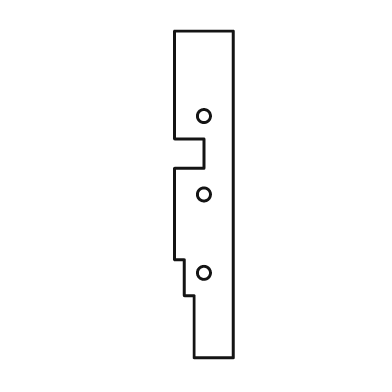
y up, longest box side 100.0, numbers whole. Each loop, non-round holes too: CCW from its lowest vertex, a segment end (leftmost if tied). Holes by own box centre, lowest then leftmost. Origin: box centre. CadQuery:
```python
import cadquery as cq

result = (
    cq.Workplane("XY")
    .moveTo(-3.0, -50.0)
    .lineTo(9.0, -50.0)
    .lineTo(9.0, 50.0)
    .lineTo(-9.0, 50.0)
    .lineTo(-9.0, 17.0)
    .lineTo(0.0, 17.0)
    .lineTo(0.0, 8.0)
    .lineTo(-9.0, 8.0)
    .lineTo(-9.0, -20.0)
    .lineTo(-6.0, -20.0)
    .lineTo(-6.0, -31.0)
    .lineTo(-3.0, -31.0)
    .close()
    .moveTo(0.0, -24.0)
    .circle(2.0)
    .moveTo(0.0, 0.0)
    .circle(2.0)
    .moveTo(0.0, 24.0)
    .circle(2.0)
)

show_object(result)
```